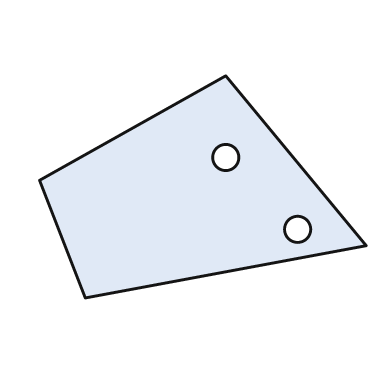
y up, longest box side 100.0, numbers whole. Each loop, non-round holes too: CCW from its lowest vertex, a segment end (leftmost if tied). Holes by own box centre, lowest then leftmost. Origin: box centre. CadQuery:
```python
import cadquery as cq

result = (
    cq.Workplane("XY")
    .moveTo(-36.0, -34.0)
    .lineTo(50.0, -18.0)
    .lineTo(7.0, 34.0)
    .lineTo(-50.0, 2.0)
    .close()
    .moveTo(29.0, -13.0)
    .circle(4.0)
    .moveTo(7.0, 9.0)
    .circle(4.0)
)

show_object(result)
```